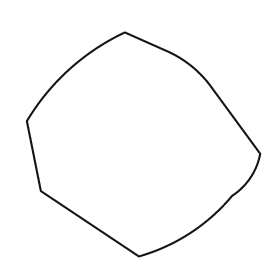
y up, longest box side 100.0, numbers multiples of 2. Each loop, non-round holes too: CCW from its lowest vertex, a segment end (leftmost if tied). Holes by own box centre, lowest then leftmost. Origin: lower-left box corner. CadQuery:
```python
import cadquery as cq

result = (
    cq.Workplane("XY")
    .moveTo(48.0, 0.0)
    .threePointArc((70.0, 10.0), (88.0, 26.0))
    .threePointArc((96.0, 34.0), (100.0, 44.0))
    .lineTo(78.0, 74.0)
    .threePointArc((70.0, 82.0), (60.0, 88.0))
    .lineTo(42.0, 96.0)
    .threePointArc((18.0, 80.0), (0.0, 58.0))
    .lineTo(6.0, 28.0)
    .close()
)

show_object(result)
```